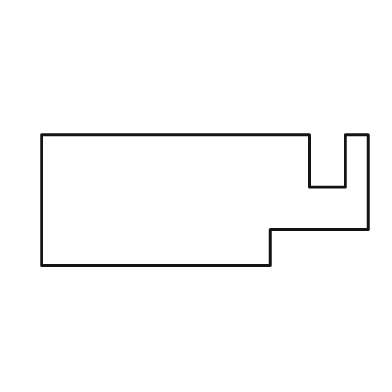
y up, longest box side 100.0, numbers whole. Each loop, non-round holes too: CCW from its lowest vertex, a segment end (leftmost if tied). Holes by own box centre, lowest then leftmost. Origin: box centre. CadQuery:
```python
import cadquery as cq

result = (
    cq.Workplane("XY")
    .moveTo(-50.0, -20.0)
    .lineTo(20.0, -20.0)
    .lineTo(20.0, -9.0)
    .lineTo(50.0, -9.0)
    .lineTo(50.0, 20.0)
    .lineTo(43.0, 20.0)
    .lineTo(43.0, 4.0)
    .lineTo(32.0, 4.0)
    .lineTo(32.0, 20.0)
    .lineTo(-50.0, 20.0)
    .close()
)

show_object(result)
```